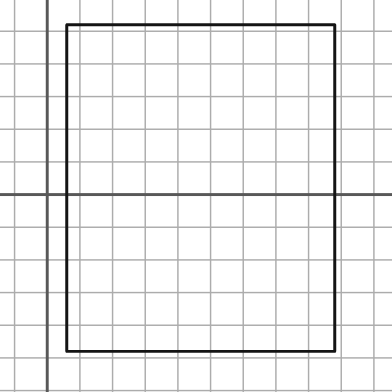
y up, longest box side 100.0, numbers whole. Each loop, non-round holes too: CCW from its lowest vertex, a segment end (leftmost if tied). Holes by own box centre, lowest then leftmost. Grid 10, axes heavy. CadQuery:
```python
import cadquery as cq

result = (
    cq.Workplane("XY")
    .moveTo(6.0, -48.0)
    .lineTo(88.0, -48.0)
    .lineTo(88.0, 52.0)
    .lineTo(6.0, 52.0)
    .close()
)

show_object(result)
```